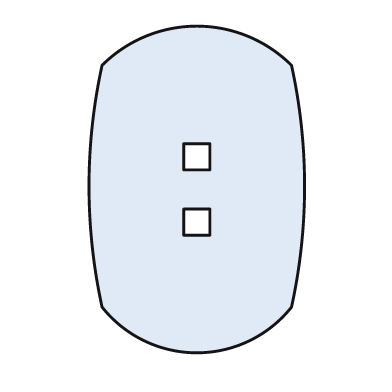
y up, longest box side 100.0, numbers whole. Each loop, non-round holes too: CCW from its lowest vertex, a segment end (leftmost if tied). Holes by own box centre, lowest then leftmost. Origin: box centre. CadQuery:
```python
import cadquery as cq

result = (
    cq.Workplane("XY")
    .moveTo(-29.0, -36.0)
    .threePointArc((0.0, -50.0), (29.0, -36.0))
    .threePointArc((33.0, 1.0), (29.0, 38.0))
    .threePointArc((0.0, 50.0), (-29.0, 38.0))
    .threePointArc((-33.0, 1.0), (-29.0, -36.0))
    .close()
    .moveTo(-4.0, -14.0)
    .lineTo(4.0, -14.0)
    .lineTo(4.0, -6.0)
    .lineTo(-4.0, -6.0)
    .close()
    .moveTo(-4.0, 6.0)
    .lineTo(4.0, 6.0)
    .lineTo(4.0, 14.0)
    .lineTo(-4.0, 14.0)
    .close()
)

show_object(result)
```